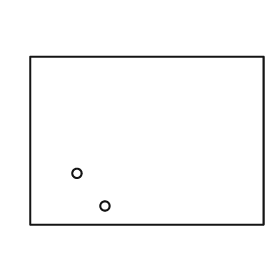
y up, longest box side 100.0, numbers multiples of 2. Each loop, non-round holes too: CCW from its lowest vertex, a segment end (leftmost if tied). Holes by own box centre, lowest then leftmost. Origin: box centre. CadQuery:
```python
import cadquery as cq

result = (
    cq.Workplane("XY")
    .moveTo(-50.0, -36.0)
    .lineTo(50.0, -36.0)
    .lineTo(50.0, 36.0)
    .lineTo(-50.0, 36.0)
    .close()
    .moveTo(-18.0, -28.0)
    .circle(2.0)
    .moveTo(-30.0, -14.0)
    .circle(2.0)
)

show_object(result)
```